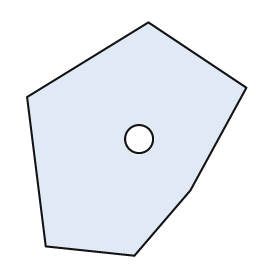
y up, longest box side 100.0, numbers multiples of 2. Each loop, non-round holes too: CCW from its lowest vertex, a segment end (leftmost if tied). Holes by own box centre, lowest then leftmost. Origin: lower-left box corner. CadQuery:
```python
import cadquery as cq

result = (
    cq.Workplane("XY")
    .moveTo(46.0, 0.0)
    .lineTo(70.0, 28.0)
    .lineTo(94.0, 72.0)
    .lineTo(52.0, 100.0)
    .lineTo(0.0, 68.0)
    .lineTo(8.0, 4.0)
    .close()
    .moveTo(48.0, 50.0)
    .circle(6.0)
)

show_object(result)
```